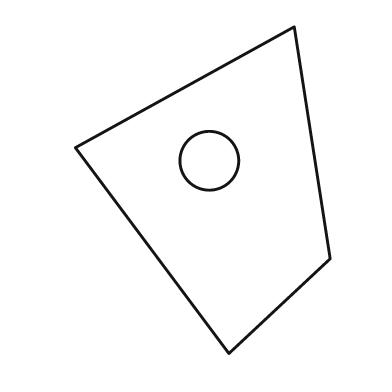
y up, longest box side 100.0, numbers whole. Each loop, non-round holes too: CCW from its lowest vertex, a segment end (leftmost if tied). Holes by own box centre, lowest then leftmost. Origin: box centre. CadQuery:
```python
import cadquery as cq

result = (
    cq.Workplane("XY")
    .moveTo(8.0, -50.0)
    .lineTo(39.0, -21.0)
    .lineTo(28.0, 50.0)
    .lineTo(-39.0, 13.0)
    .close()
    .moveTo(2.0, 9.0)
    .circle(9.0)
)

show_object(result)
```